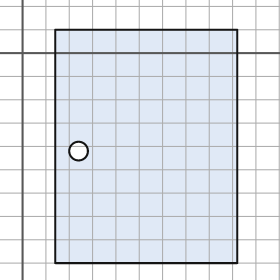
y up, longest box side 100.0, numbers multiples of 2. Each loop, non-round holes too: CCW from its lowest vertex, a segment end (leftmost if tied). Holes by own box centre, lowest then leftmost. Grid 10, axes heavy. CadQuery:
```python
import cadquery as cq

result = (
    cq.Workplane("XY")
    .moveTo(14.0, -90.0)
    .lineTo(92.0, -90.0)
    .lineTo(92.0, 10.0)
    .lineTo(14.0, 10.0)
    .close()
    .moveTo(24.0, -42.0)
    .circle(4.0)
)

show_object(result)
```